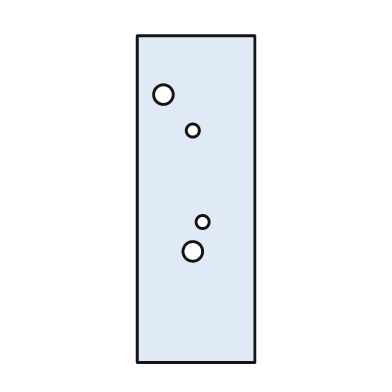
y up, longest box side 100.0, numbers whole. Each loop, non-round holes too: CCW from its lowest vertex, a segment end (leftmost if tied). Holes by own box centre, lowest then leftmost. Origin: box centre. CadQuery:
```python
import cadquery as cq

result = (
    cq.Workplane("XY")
    .moveTo(-18.0, -50.0)
    .lineTo(18.0, -50.0)
    .lineTo(18.0, 50.0)
    .lineTo(-18.0, 50.0)
    .close()
    .moveTo(-1.0, -16.0)
    .circle(3.0)
    .moveTo(2.0, -7.0)
    .circle(2.0)
    .moveTo(-1.0, 21.0)
    .circle(2.0)
    .moveTo(-10.0, 32.0)
    .circle(3.0)
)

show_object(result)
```